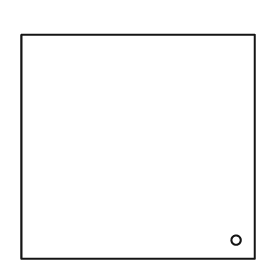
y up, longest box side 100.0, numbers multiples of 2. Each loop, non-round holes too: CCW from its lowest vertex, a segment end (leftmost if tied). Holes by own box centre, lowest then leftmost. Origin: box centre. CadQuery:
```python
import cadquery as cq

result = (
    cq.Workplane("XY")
    .moveTo(-50.0, -48.0)
    .lineTo(50.0, -48.0)
    .lineTo(50.0, 48.0)
    .lineTo(-50.0, 48.0)
    .close()
    .moveTo(42.0, -40.0)
    .circle(2.0)
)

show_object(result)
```